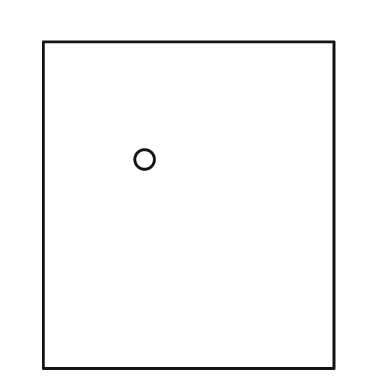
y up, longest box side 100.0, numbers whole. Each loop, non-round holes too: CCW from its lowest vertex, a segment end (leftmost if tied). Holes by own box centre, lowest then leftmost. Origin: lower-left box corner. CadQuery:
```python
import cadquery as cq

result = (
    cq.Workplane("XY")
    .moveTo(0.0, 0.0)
    .lineTo(89.0, 0.0)
    .lineTo(89.0, 100.0)
    .lineTo(0.0, 100.0)
    .close()
    .moveTo(31.0, 64.0)
    .circle(3.0)
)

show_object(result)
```